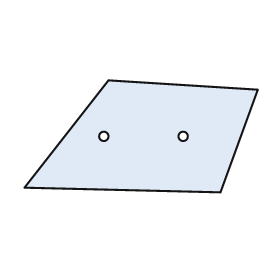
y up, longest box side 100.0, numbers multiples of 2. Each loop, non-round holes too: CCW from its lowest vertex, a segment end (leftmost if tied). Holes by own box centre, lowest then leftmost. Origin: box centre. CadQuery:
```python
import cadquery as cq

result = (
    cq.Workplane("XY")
    .moveTo(34.0, -24.0)
    .lineTo(50.0, 20.0)
    .lineTo(-14.0, 24.0)
    .lineTo(-50.0, -22.0)
    .close()
    .moveTo(-16.0, 0.0)
    .circle(2.0)
    .moveTo(18.0, 0.0)
    .circle(2.0)
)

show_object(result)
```